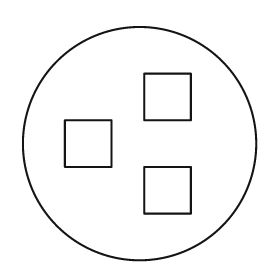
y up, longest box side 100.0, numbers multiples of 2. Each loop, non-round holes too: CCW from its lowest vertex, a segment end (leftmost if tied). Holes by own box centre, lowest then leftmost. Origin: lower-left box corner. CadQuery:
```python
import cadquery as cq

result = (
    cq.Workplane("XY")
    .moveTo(50.0, 50.0)
    .circle(50.0)
    .moveTo(52.0, 20.0)
    .lineTo(72.0, 20.0)
    .lineTo(72.0, 40.0)
    .lineTo(52.0, 40.0)
    .close()
    .moveTo(18.0, 40.0)
    .lineTo(38.0, 40.0)
    .lineTo(38.0, 60.0)
    .lineTo(18.0, 60.0)
    .close()
    .moveTo(52.0, 60.0)
    .lineTo(72.0, 60.0)
    .lineTo(72.0, 80.0)
    .lineTo(52.0, 80.0)
    .close()
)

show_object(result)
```